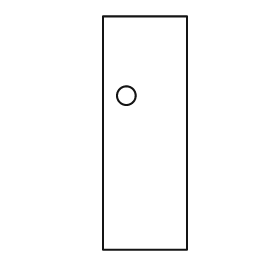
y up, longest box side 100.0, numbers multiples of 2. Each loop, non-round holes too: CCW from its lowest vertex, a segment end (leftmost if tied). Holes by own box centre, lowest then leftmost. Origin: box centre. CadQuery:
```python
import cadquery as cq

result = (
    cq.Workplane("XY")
    .moveTo(-18.0, -50.0)
    .lineTo(18.0, -50.0)
    .lineTo(18.0, 50.0)
    .lineTo(-18.0, 50.0)
    .close()
    .moveTo(-8.0, 16.0)
    .circle(4.0)
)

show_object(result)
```